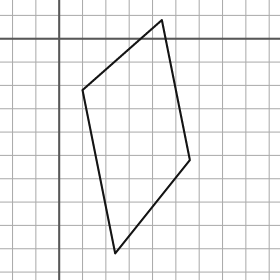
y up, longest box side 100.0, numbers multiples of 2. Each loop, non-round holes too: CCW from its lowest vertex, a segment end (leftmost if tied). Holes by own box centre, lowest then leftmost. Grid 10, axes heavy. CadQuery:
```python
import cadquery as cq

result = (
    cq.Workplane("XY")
    .moveTo(24.0, -92.0)
    .lineTo(56.0, -52.0)
    .lineTo(44.0, 8.0)
    .lineTo(10.0, -22.0)
    .close()
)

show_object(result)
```